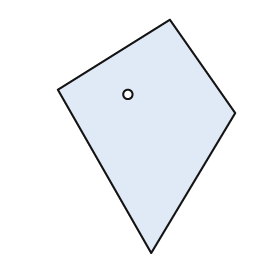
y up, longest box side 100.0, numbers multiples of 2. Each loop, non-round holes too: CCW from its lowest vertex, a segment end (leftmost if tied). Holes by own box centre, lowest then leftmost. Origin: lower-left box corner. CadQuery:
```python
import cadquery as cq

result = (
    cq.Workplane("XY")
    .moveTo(40.0, 0.0)
    .lineTo(76.0, 60.0)
    .lineTo(48.0, 100.0)
    .lineTo(0.0, 70.0)
    .close()
    .moveTo(30.0, 68.0)
    .circle(2.0)
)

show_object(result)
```